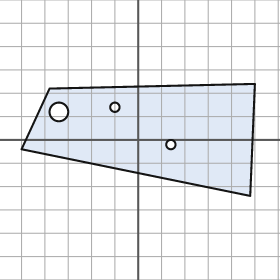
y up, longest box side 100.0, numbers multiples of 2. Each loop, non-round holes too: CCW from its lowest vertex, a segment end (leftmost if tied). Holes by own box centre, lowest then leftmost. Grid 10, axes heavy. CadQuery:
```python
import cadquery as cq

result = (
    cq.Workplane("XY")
    .moveTo(48.0, -24.0)
    .lineTo(50.0, 24.0)
    .lineTo(-38.0, 22.0)
    .lineTo(-50.0, -4.0)
    .close()
    .moveTo(14.0, -2.0)
    .circle(2.0)
    .moveTo(-34.0, 12.0)
    .circle(4.0)
    .moveTo(-10.0, 14.0)
    .circle(2.0)
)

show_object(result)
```